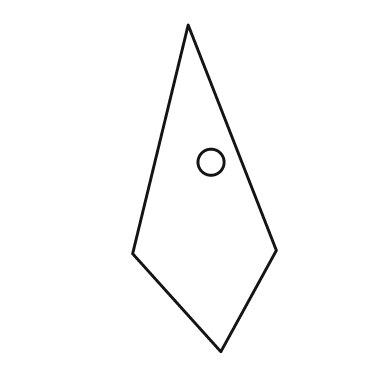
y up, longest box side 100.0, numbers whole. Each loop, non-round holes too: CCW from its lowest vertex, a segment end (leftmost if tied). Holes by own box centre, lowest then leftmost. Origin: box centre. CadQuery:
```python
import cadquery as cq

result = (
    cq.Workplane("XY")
    .moveTo(5.0, -50.0)
    .lineTo(22.0, -19.0)
    .lineTo(-5.0, 50.0)
    .lineTo(-22.0, -20.0)
    .close()
    .moveTo(2.0, 8.0)
    .circle(4.0)
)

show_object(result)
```